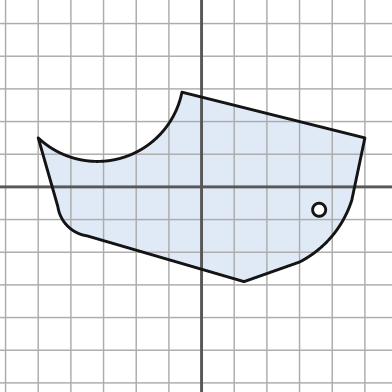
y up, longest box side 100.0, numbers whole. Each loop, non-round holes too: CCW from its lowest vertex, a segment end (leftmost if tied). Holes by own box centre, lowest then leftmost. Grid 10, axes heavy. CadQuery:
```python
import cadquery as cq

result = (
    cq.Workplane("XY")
    .moveTo(13.0, -29.0)
    .lineTo(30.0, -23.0)
    .threePointArc((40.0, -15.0), (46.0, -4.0))
    .lineTo(50.0, 15.0)
    .lineTo(-6.0, 29.0)
    .threePointArc((-24.0, 9.0), (-50.0, 15.0))
    .lineTo(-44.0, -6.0)
    .threePointArc((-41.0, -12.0), (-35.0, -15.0))
    .close()
    .moveTo(36.0, -7.0)
    .circle(2.0)
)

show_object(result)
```